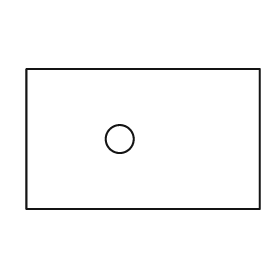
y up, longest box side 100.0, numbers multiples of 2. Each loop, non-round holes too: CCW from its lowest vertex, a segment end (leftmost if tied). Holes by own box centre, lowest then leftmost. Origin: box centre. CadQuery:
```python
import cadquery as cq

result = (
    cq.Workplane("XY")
    .moveTo(-50.0, -30.0)
    .lineTo(50.0, -30.0)
    .lineTo(50.0, 30.0)
    .lineTo(-50.0, 30.0)
    .close()
    .moveTo(-10.0, 0.0)
    .circle(6.0)
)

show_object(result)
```